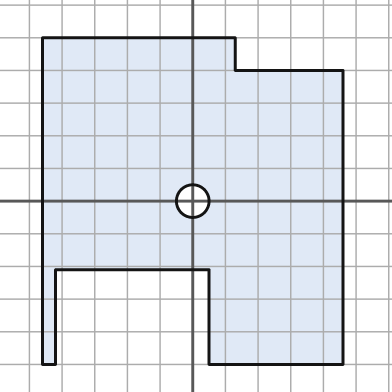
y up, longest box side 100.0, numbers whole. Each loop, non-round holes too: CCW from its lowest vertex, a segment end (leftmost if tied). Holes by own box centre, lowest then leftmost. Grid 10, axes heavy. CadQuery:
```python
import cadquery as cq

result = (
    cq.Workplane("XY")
    .moveTo(-46.0, -50.0)
    .lineTo(-42.0, -50.0)
    .lineTo(-42.0, -21.0)
    .lineTo(5.0, -21.0)
    .lineTo(5.0, -50.0)
    .lineTo(46.0, -50.0)
    .lineTo(46.0, 40.0)
    .lineTo(13.0, 40.0)
    .lineTo(13.0, 50.0)
    .lineTo(-46.0, 50.0)
    .close()
    .moveTo(0.0, 0.0)
    .circle(5.0)
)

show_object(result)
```